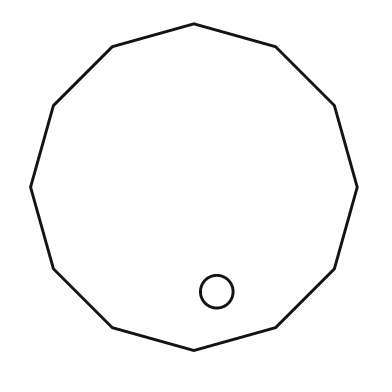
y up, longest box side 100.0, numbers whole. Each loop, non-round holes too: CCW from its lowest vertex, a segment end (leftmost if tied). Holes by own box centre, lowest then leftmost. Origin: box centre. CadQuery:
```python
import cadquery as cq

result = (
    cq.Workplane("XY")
    .moveTo(0.0, -50.0)
    .lineTo(25.0, -43.0)
    .lineTo(43.0, -25.0)
    .lineTo(50.0, 0.0)
    .lineTo(43.0, 25.0)
    .lineTo(25.0, 43.0)
    .lineTo(0.0, 50.0)
    .lineTo(-25.0, 43.0)
    .lineTo(-43.0, 25.0)
    .lineTo(-50.0, 0.0)
    .lineTo(-43.0, -25.0)
    .lineTo(-25.0, -43.0)
    .close()
    .moveTo(7.0, -32.0)
    .circle(5.0)
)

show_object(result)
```